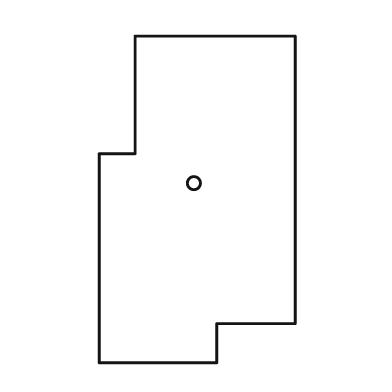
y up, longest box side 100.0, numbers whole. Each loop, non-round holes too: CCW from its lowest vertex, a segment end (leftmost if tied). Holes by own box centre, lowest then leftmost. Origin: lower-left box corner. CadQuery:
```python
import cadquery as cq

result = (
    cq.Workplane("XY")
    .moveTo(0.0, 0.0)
    .lineTo(36.0, 0.0)
    .lineTo(36.0, 12.0)
    .lineTo(60.0, 12.0)
    .lineTo(60.0, 100.0)
    .lineTo(11.0, 100.0)
    .lineTo(11.0, 64.0)
    .lineTo(0.0, 64.0)
    .close()
    .moveTo(29.0, 55.0)
    .circle(2.0)
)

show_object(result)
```